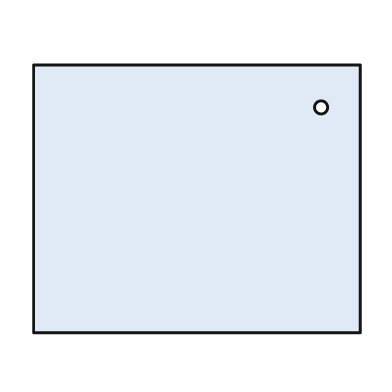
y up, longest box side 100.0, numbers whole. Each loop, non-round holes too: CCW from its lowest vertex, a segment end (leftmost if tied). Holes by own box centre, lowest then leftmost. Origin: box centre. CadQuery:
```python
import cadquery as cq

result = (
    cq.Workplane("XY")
    .moveTo(-50.0, -41.0)
    .lineTo(50.0, -41.0)
    .lineTo(50.0, 41.0)
    .lineTo(-50.0, 41.0)
    .close()
    .moveTo(38.0, 28.0)
    .circle(2.0)
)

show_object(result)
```